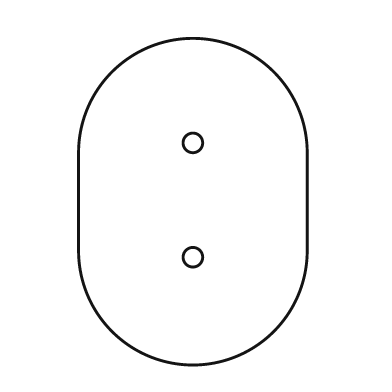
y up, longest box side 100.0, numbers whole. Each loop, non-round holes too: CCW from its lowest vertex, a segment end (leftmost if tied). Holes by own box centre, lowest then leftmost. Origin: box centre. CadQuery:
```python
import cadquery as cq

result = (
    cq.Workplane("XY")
    .moveTo(-35.0, -15.0)
    .threePointArc((0.0, -50.0), (35.0, -15.0))
    .lineTo(35.0, 15.0)
    .threePointArc((0.0, 50.0), (-35.0, 15.0))
    .close()
    .moveTo(0.0, -17.0)
    .circle(3.0)
    .moveTo(0.0, 18.0)
    .circle(3.0)
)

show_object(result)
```